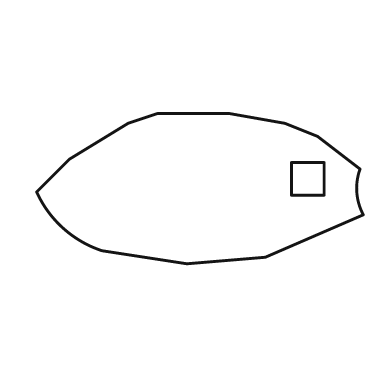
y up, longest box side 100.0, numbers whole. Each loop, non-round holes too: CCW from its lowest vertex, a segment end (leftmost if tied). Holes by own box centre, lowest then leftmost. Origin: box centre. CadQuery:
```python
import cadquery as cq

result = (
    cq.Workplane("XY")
    .moveTo(-4.0, -23.0)
    .lineTo(20.0, -21.0)
    .lineTo(50.0, -8.0)
    .threePointArc((48.0, -1.0), (49.0, 6.0))
    .lineTo(36.0, 16.0)
    .lineTo(26.0, 20.0)
    .lineTo(9.0, 23.0)
    .lineTo(-13.0, 23.0)
    .lineTo(-22.0, 20.0)
    .lineTo(-40.0, 9.0)
    .lineTo(-50.0, -1.0)
    .threePointArc((-42.0, -12.0), (-30.0, -19.0))
    .close()
    .moveTo(28.0, -2.0)
    .lineTo(38.0, -2.0)
    .lineTo(38.0, 8.0)
    .lineTo(28.0, 8.0)
    .close()
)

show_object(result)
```